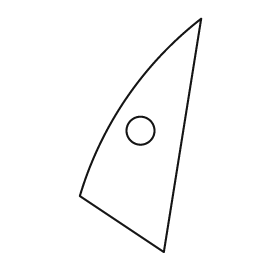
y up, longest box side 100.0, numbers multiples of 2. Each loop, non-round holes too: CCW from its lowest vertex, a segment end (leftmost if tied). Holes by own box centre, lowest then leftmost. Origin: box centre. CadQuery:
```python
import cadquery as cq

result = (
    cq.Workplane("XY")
    .moveTo(10.0, -50.0)
    .lineTo(26.0, 50.0)
    .threePointArc((-6.0, 16.0), (-26.0, -26.0))
    .close()
    .moveTo(0.0, 2.0)
    .circle(6.0)
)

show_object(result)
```